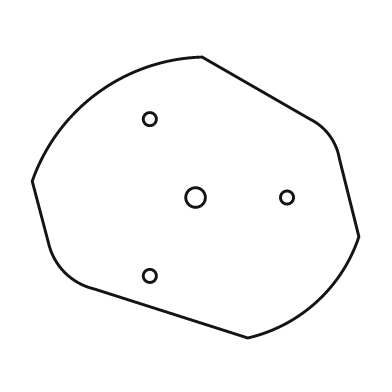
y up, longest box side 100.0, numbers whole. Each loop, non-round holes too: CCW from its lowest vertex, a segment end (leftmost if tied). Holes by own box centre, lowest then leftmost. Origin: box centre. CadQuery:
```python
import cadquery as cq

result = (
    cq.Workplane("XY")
    .moveTo(16.0, -43.0)
    .threePointArc((37.0, -32.0), (50.0, -12.0))
    .lineTo(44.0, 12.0)
    .threePointArc((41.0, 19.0), (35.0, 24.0))
    .lineTo(2.0, 43.0)
    .threePointArc((-30.0, 32.0), (-50.0, 5.0))
    .lineTo(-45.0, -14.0)
    .threePointArc((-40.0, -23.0), (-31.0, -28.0))
    .close()
    .moveTo(-14.0, -24.0)
    .circle(2.0)
    .moveTo(0.0, 0.0)
    .circle(3.0)
    .moveTo(28.0, 0.0)
    .circle(2.0)
    .moveTo(-14.0, 24.0)
    .circle(2.0)
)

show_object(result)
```